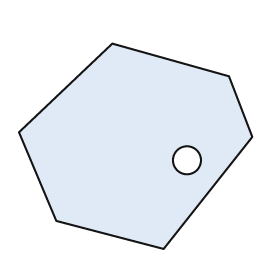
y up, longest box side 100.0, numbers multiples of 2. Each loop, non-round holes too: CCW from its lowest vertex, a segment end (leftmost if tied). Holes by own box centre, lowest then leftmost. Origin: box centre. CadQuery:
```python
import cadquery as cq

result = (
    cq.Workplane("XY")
    .moveTo(12.0, -44.0)
    .lineTo(50.0, 4.0)
    .lineTo(40.0, 30.0)
    .lineTo(-10.0, 44.0)
    .lineTo(-50.0, 6.0)
    .lineTo(-34.0, -32.0)
    .close()
    .moveTo(22.0, -6.0)
    .circle(6.0)
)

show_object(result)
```